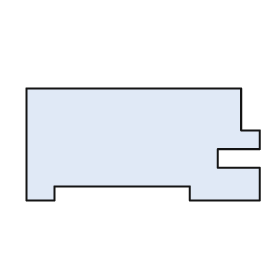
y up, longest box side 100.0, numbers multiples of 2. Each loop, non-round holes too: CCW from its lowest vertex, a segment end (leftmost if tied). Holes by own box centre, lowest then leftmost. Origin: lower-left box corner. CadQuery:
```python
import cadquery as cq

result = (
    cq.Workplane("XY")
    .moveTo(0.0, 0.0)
    .lineTo(12.0, 0.0)
    .lineTo(12.0, 6.0)
    .lineTo(70.0, 6.0)
    .lineTo(70.0, 0.0)
    .lineTo(100.0, 0.0)
    .lineTo(100.0, 14.0)
    .lineTo(82.0, 14.0)
    .lineTo(82.0, 22.0)
    .lineTo(100.0, 22.0)
    .lineTo(100.0, 30.0)
    .lineTo(92.0, 30.0)
    .lineTo(92.0, 48.0)
    .lineTo(0.0, 48.0)
    .close()
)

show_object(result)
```